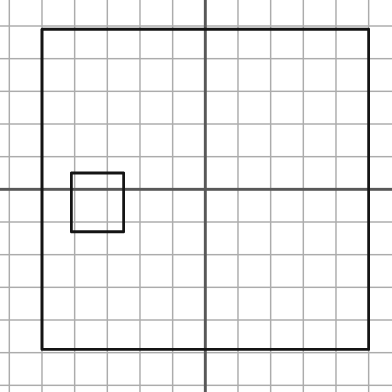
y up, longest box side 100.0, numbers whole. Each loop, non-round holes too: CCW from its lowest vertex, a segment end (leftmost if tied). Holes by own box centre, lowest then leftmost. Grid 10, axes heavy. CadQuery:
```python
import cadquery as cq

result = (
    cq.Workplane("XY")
    .moveTo(-50.0, -49.0)
    .lineTo(50.0, -49.0)
    .lineTo(50.0, 49.0)
    .lineTo(-50.0, 49.0)
    .close()
    .moveTo(-41.0, -13.0)
    .lineTo(-25.0, -13.0)
    .lineTo(-25.0, 5.0)
    .lineTo(-41.0, 5.0)
    .close()
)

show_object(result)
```